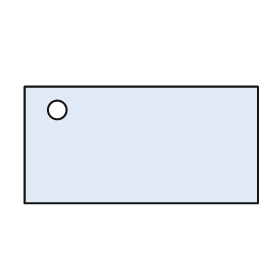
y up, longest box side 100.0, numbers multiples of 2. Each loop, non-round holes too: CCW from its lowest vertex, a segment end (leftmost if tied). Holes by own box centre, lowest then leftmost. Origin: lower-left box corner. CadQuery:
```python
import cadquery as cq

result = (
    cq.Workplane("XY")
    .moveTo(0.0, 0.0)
    .lineTo(100.0, 0.0)
    .lineTo(100.0, 50.0)
    .lineTo(0.0, 50.0)
    .close()
    .moveTo(14.0, 40.0)
    .circle(4.0)
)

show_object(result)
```